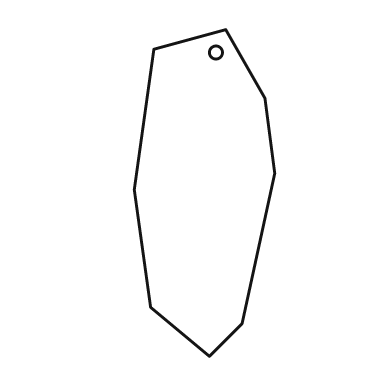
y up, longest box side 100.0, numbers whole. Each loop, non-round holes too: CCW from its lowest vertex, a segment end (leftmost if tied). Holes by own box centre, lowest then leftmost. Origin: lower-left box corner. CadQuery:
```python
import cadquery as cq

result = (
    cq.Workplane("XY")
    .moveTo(23.0, 0.0)
    .lineTo(33.0, 10.0)
    .lineTo(43.0, 56.0)
    .lineTo(40.0, 79.0)
    .lineTo(28.0, 100.0)
    .lineTo(6.0, 94.0)
    .lineTo(0.0, 51.0)
    .lineTo(5.0, 15.0)
    .close()
    .moveTo(25.0, 93.0)
    .circle(2.0)
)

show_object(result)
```